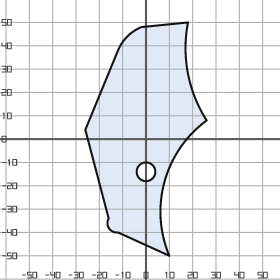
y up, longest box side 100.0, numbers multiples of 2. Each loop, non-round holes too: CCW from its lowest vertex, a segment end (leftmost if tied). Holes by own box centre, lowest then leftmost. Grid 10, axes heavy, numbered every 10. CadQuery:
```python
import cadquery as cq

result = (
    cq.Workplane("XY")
    .moveTo(10.0, -50.0)
    .threePointArc((8.0, -18.0), (26.0, 8.0))
    .threePointArc((18.0, 28.0), (18.0, 50.0))
    .lineTo(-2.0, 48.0)
    .threePointArc((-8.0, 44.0), (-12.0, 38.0))
    .lineTo(-26.0, 4.0)
    .lineTo(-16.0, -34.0)
    .threePointArc((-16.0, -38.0), (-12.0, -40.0))
    .close()
    .moveTo(0.0, -14.0)
    .circle(4.0)
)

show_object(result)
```